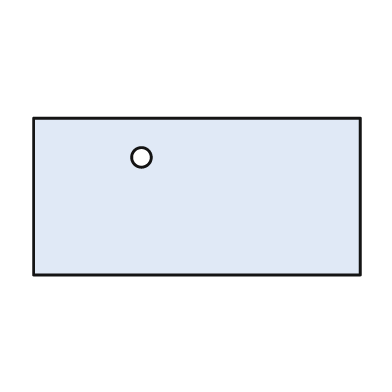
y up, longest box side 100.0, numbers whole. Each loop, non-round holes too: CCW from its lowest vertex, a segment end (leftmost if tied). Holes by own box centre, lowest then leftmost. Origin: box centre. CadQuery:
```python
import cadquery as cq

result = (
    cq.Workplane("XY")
    .moveTo(-50.0, -24.0)
    .lineTo(50.0, -24.0)
    .lineTo(50.0, 24.0)
    .lineTo(-50.0, 24.0)
    .close()
    .moveTo(-17.0, 12.0)
    .circle(3.0)
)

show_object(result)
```